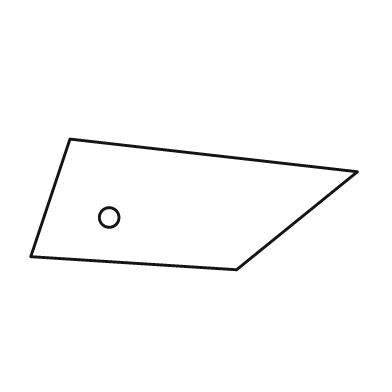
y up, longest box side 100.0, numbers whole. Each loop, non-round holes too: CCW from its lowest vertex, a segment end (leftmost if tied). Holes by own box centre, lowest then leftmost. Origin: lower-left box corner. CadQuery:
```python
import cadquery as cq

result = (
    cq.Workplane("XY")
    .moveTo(63.0, 0.0)
    .lineTo(100.0, 30.0)
    .lineTo(12.0, 40.0)
    .lineTo(0.0, 4.0)
    .close()
    .moveTo(24.0, 16.0)
    .circle(3.0)
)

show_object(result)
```